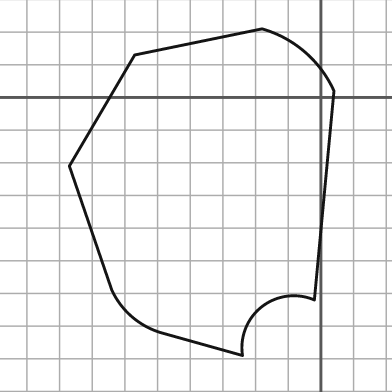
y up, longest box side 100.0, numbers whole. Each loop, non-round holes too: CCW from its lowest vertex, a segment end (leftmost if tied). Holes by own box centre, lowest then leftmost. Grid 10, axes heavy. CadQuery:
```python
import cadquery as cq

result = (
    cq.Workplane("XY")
    .moveTo(-24.0, -79.0)
    .threePointArc((-18.0, -64.0), (-2.0, -62.0))
    .lineTo(4.0, 2.0)
    .threePointArc((-5.0, 14.0), (-18.0, 21.0))
    .lineTo(-57.0, 13.0)
    .lineTo(-77.0, -21.0)
    .lineTo(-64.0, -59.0)
    .threePointArc((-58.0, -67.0), (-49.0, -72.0))
    .close()
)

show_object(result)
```